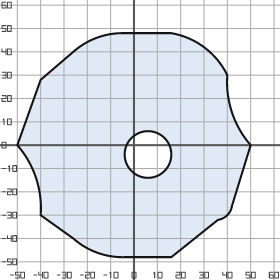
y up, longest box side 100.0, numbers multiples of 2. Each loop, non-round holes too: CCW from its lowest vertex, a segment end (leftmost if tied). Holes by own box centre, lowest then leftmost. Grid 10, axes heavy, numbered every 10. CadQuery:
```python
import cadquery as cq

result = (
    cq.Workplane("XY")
    .moveTo(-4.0, -48.0)
    .lineTo(16.0, -48.0)
    .lineTo(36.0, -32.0)
    .threePointArc((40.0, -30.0), (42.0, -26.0))
    .lineTo(50.0, 0.0)
    .threePointArc((42.0, 14.0), (40.0, 30.0))
    .threePointArc((30.0, 42.0), (16.0, 48.0))
    .lineTo(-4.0, 48.0)
    .threePointArc((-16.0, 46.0), (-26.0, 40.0))
    .lineTo(-40.0, 28.0)
    .lineTo(-50.0, 0.0)
    .threePointArc((-42.0, -14.0), (-40.0, -30.0))
    .lineTo(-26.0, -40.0)
    .threePointArc((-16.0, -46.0), (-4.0, -48.0))
    .close()
    .moveTo(6.0, -4.0)
    .circle(10.0)
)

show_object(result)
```